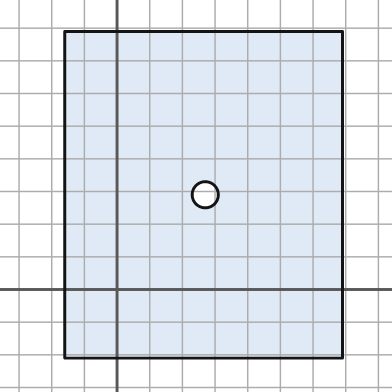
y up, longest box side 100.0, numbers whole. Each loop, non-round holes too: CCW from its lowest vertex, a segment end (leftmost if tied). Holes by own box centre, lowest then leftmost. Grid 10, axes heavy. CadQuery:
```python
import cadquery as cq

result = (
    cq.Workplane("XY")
    .moveTo(-16.0, -21.0)
    .lineTo(69.0, -21.0)
    .lineTo(69.0, 79.0)
    .lineTo(-16.0, 79.0)
    .close()
    .moveTo(27.0, 29.0)
    .circle(4.0)
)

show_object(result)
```